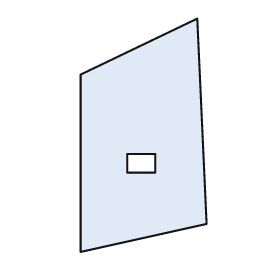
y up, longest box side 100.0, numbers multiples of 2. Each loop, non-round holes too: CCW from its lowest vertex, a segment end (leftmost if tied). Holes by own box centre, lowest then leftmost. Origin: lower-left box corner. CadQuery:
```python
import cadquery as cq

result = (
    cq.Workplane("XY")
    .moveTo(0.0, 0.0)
    .lineTo(54.0, 12.0)
    .lineTo(50.0, 100.0)
    .lineTo(0.0, 76.0)
    .close()
    .moveTo(20.0, 34.0)
    .lineTo(32.0, 34.0)
    .lineTo(32.0, 42.0)
    .lineTo(20.0, 42.0)
    .close()
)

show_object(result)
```